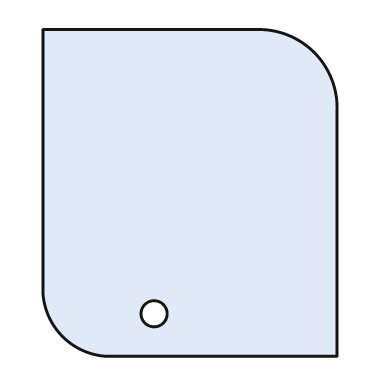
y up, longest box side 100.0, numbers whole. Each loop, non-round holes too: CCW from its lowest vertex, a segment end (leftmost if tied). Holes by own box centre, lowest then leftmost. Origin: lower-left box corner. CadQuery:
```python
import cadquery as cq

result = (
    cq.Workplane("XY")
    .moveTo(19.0, 0.0)
    .lineTo(90.0, 0.0)
    .lineTo(90.0, 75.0)
    .threePointArc((83.0, 93.0), (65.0, 100.0))
    .lineTo(0.0, 100.0)
    .lineTo(0.0, 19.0)
    .threePointArc((6.0, 6.0), (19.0, 0.0))
    .close()
    .moveTo(34.0, 13.0)
    .circle(4.0)
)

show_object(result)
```